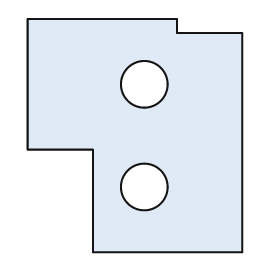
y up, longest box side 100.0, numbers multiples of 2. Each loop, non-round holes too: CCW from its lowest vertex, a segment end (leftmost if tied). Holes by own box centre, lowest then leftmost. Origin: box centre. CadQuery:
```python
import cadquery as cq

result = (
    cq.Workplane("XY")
    .moveTo(-18.0, -50.0)
    .lineTo(46.0, -50.0)
    .lineTo(46.0, 44.0)
    .lineTo(18.0, 44.0)
    .lineTo(18.0, 50.0)
    .lineTo(-46.0, 50.0)
    .lineTo(-46.0, -6.0)
    .lineTo(-18.0, -6.0)
    .close()
    .moveTo(4.0, -22.0)
    .circle(10.0)
    .moveTo(4.0, 22.0)
    .circle(10.0)
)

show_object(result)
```